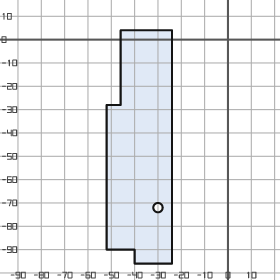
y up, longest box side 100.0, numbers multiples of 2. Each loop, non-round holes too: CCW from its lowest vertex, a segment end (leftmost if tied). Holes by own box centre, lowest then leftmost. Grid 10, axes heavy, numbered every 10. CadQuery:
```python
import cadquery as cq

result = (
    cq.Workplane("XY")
    .moveTo(-40.0, -96.0)
    .lineTo(-24.0, -96.0)
    .lineTo(-24.0, 4.0)
    .lineTo(-46.0, 4.0)
    .lineTo(-46.0, -28.0)
    .lineTo(-52.0, -28.0)
    .lineTo(-52.0, -90.0)
    .lineTo(-40.0, -90.0)
    .close()
    .moveTo(-30.0, -72.0)
    .circle(2.0)
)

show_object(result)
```